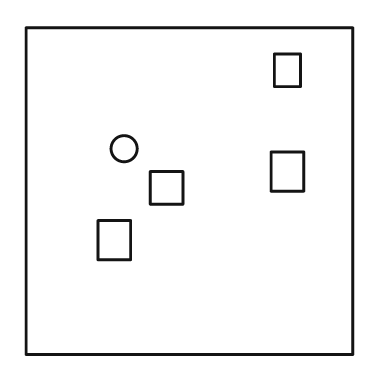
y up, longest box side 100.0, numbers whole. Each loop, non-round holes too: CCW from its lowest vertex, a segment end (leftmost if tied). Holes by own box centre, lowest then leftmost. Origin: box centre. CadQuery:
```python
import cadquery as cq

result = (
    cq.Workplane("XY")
    .moveTo(-50.0, -50.0)
    .lineTo(50.0, -50.0)
    .lineTo(50.0, 50.0)
    .lineTo(-50.0, 50.0)
    .close()
    .moveTo(-28.0, -21.0)
    .lineTo(-18.0, -21.0)
    .lineTo(-18.0, -9.0)
    .lineTo(-28.0, -9.0)
    .close()
    .moveTo(-12.0, -4.0)
    .lineTo(-2.0, -4.0)
    .lineTo(-2.0, 6.0)
    .lineTo(-12.0, 6.0)
    .close()
    .moveTo(25.0, 0.0)
    .lineTo(35.0, 0.0)
    .lineTo(35.0, 12.0)
    .lineTo(25.0, 12.0)
    .close()
    .moveTo(-20.0, 13.0)
    .circle(4.0)
    .moveTo(26.0, 32.0)
    .lineTo(34.0, 32.0)
    .lineTo(34.0, 42.0)
    .lineTo(26.0, 42.0)
    .close()
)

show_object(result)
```